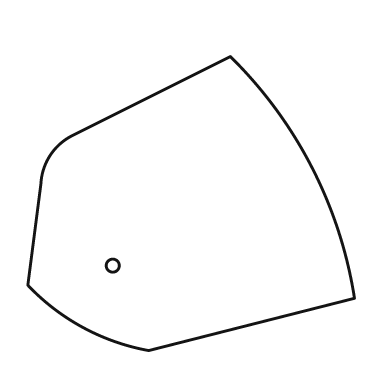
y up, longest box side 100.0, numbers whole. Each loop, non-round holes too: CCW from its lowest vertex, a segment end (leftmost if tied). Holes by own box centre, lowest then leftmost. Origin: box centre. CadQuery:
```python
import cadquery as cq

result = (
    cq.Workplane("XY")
    .moveTo(-13.0, -45.0)
    .lineTo(50.0, -29.0)
    .threePointArc((37.0, 11.0), (12.0, 45.0))
    .lineTo(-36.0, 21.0)
    .threePointArc((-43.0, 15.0), (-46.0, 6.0))
    .lineTo(-50.0, -25.0)
    .threePointArc((-33.0, -38.0), (-13.0, -45.0))
    .close()
    .moveTo(-24.0, -19.0)
    .circle(2.0)
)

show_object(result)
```